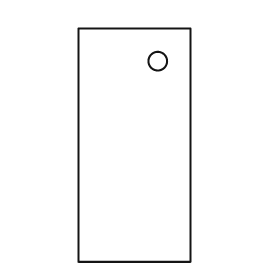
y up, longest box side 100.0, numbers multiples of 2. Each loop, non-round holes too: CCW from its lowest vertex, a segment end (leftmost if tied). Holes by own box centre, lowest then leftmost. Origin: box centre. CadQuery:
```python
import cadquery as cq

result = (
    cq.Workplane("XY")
    .moveTo(-24.0, -50.0)
    .lineTo(24.0, -50.0)
    .lineTo(24.0, 50.0)
    .lineTo(-24.0, 50.0)
    .close()
    .moveTo(10.0, 36.0)
    .circle(4.0)
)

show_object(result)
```